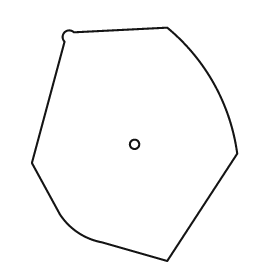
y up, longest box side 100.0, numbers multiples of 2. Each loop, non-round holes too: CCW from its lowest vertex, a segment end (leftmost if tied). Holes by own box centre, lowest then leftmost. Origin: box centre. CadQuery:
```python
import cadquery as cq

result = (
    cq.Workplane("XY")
    .moveTo(14.0, -50.0)
    .lineTo(44.0, -4.0)
    .threePointArc((34.0, 26.0), (14.0, 50.0))
    .lineTo(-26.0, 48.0)
    .threePointArc((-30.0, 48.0), (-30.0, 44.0))
    .lineTo(-44.0, -8.0)
    .lineTo(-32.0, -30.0)
    .threePointArc((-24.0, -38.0), (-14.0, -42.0))
    .close()
    .moveTo(0.0, 0.0)
    .circle(2.0)
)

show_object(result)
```